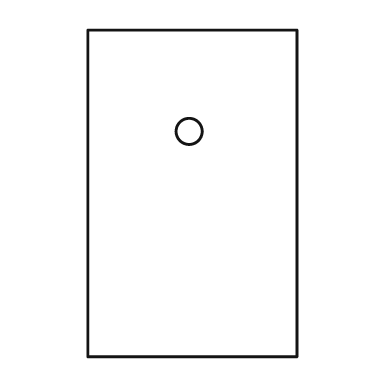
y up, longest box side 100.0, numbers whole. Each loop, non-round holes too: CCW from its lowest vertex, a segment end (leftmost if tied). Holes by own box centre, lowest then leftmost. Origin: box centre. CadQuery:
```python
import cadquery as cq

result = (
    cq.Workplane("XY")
    .moveTo(-32.0, -50.0)
    .lineTo(32.0, -50.0)
    .lineTo(32.0, 50.0)
    .lineTo(-32.0, 50.0)
    .close()
    .moveTo(-1.0, 19.0)
    .circle(4.0)
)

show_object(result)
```